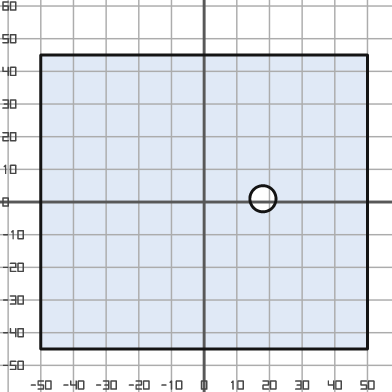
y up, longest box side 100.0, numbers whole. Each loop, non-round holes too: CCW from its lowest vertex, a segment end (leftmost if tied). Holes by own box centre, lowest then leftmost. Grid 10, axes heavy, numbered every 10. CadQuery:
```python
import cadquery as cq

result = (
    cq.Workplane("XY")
    .moveTo(-50.0, -45.0)
    .lineTo(50.0, -45.0)
    .lineTo(50.0, 45.0)
    .lineTo(-50.0, 45.0)
    .close()
    .moveTo(18.0, 1.0)
    .circle(4.0)
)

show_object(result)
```